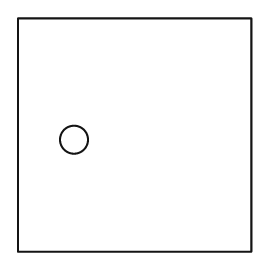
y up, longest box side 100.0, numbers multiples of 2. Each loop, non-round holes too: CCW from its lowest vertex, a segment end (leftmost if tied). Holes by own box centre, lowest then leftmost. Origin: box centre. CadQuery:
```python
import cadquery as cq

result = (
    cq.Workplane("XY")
    .moveTo(-50.0, -50.0)
    .lineTo(50.0, -50.0)
    .lineTo(50.0, 50.0)
    .lineTo(-50.0, 50.0)
    .close()
    .moveTo(-26.0, -2.0)
    .circle(6.0)
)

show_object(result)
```